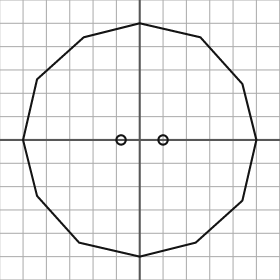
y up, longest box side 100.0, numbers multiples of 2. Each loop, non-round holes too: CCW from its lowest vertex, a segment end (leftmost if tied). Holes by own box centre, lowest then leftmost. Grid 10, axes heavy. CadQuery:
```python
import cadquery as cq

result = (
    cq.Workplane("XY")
    .moveTo(0.0, -50.0)
    .lineTo(24.0, -44.0)
    .lineTo(44.0, -26.0)
    .lineTo(50.0, 0.0)
    .lineTo(44.0, 24.0)
    .lineTo(26.0, 44.0)
    .lineTo(0.0, 50.0)
    .lineTo(-24.0, 44.0)
    .lineTo(-44.0, 26.0)
    .lineTo(-50.0, 0.0)
    .lineTo(-44.0, -24.0)
    .lineTo(-26.0, -44.0)
    .close()
    .moveTo(-8.0, 0.0)
    .circle(2.0)
    .moveTo(10.0, 0.0)
    .circle(2.0)
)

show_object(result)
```